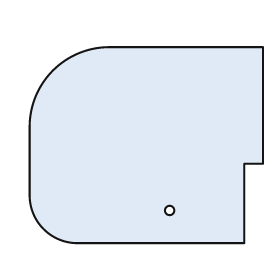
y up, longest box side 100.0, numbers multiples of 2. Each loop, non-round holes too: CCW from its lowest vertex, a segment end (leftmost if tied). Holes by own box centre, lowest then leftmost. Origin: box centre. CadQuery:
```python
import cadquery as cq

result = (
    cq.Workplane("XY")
    .moveTo(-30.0, -42.0)
    .lineTo(42.0, -42.0)
    .lineTo(42.0, -8.0)
    .lineTo(50.0, -8.0)
    .lineTo(50.0, 42.0)
    .lineTo(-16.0, 42.0)
    .threePointArc((-40.0, 32.0), (-50.0, 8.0))
    .lineTo(-50.0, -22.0)
    .threePointArc((-44.0, -36.0), (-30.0, -42.0))
    .close()
    .moveTo(10.0, -28.0)
    .circle(2.0)
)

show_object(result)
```